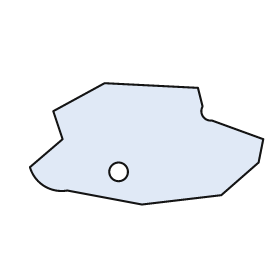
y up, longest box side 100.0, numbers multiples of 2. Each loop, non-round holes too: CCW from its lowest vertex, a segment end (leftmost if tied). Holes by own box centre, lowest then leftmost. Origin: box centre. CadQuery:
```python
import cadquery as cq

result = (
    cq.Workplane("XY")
    .moveTo(-2.0, -26.0)
    .lineTo(32.0, -22.0)
    .lineTo(48.0, -8.0)
    .lineTo(50.0, 2.0)
    .lineTo(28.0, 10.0)
    .threePointArc((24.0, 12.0), (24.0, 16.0))
    .lineTo(22.0, 24.0)
    .lineTo(-18.0, 26.0)
    .lineTo(-40.0, 14.0)
    .lineTo(-36.0, 2.0)
    .lineTo(-50.0, -10.0)
    .threePointArc((-44.0, -18.0), (-34.0, -20.0))
    .close()
    .moveTo(-12.0, -12.0)
    .circle(4.0)
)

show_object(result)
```